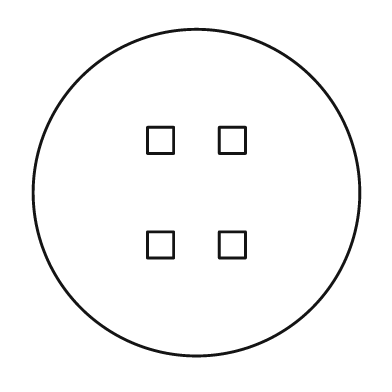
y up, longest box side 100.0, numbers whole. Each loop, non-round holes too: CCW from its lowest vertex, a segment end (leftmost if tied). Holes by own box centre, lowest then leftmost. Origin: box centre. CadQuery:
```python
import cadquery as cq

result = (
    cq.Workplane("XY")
    .moveTo(0.0, 0.0)
    .circle(50.0)
    .moveTo(-15.0, -20.0)
    .lineTo(-7.0, -20.0)
    .lineTo(-7.0, -12.0)
    .lineTo(-15.0, -12.0)
    .close()
    .moveTo(7.0, -20.0)
    .lineTo(15.0, -20.0)
    .lineTo(15.0, -12.0)
    .lineTo(7.0, -12.0)
    .close()
    .moveTo(-15.0, 12.0)
    .lineTo(-7.0, 12.0)
    .lineTo(-7.0, 20.0)
    .lineTo(-15.0, 20.0)
    .close()
    .moveTo(7.0, 12.0)
    .lineTo(15.0, 12.0)
    .lineTo(15.0, 20.0)
    .lineTo(7.0, 20.0)
    .close()
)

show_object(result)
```